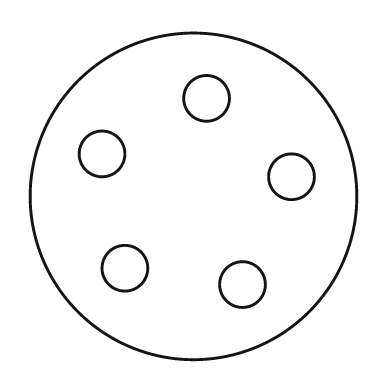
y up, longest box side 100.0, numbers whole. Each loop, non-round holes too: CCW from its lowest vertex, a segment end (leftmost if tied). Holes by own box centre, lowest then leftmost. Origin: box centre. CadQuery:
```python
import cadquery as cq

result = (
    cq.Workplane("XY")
    .moveTo(0.0, 0.0)
    .circle(50.0)
    .moveTo(15.0, -27.0)
    .circle(7.0)
    .moveTo(-21.0, -22.0)
    .circle(7.0)
    .moveTo(30.0, 6.0)
    .circle(7.0)
    .moveTo(-28.0, 13.0)
    .circle(7.0)
    .moveTo(4.0, 30.0)
    .circle(7.0)
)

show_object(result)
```